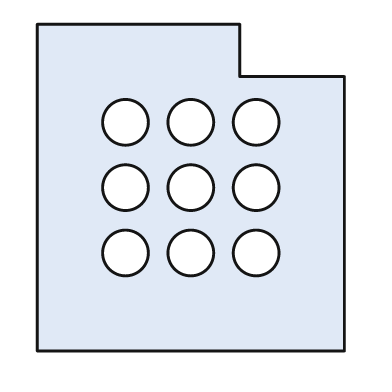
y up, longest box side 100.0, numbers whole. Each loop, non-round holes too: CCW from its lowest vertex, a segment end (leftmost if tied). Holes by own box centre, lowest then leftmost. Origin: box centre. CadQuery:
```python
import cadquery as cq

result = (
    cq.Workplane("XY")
    .moveTo(-47.0, -50.0)
    .lineTo(47.0, -50.0)
    .lineTo(47.0, 34.0)
    .lineTo(15.0, 34.0)
    .lineTo(15.0, 50.0)
    .lineTo(-47.0, 50.0)
    .close()
    .moveTo(-20.0, -20.0)
    .circle(7.0)
    .moveTo(0.0, -20.0)
    .circle(7.0)
    .moveTo(20.0, -20.0)
    .circle(7.0)
    .moveTo(-20.0, 0.0)
    .circle(7.0)
    .moveTo(0.0, 0.0)
    .circle(7.0)
    .moveTo(20.0, 0.0)
    .circle(7.0)
    .moveTo(-20.0, 20.0)
    .circle(7.0)
    .moveTo(0.0, 20.0)
    .circle(7.0)
    .moveTo(20.0, 20.0)
    .circle(7.0)
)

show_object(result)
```